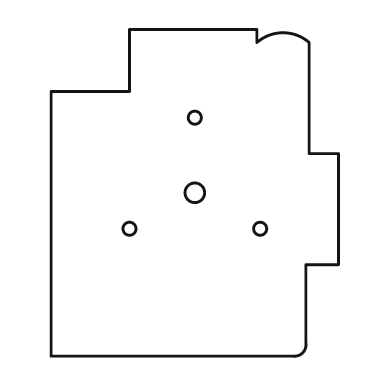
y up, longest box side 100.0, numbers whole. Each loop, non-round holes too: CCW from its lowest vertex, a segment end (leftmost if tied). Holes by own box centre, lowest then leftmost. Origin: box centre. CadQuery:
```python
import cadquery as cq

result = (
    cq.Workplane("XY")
    .moveTo(-44.0, -50.0)
    .lineTo(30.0, -50.0)
    .threePointArc((33.0, -49.0), (34.0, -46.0))
    .lineTo(34.0, -22.0)
    .lineTo(44.0, -22.0)
    .lineTo(44.0, 12.0)
    .lineTo(35.0, 12.0)
    .lineTo(35.0, 46.0)
    .threePointArc((27.0, 49.0), (19.0, 46.0))
    .lineTo(19.0, 50.0)
    .lineTo(-20.0, 50.0)
    .lineTo(-20.0, 31.0)
    .lineTo(-44.0, 31.0)
    .close()
    .moveTo(-20.0, -11.0)
    .circle(2.0)
    .moveTo(20.0, -11.0)
    .circle(2.0)
    .moveTo(0.0, 0.0)
    .circle(3.0)
    .moveTo(0.0, 23.0)
    .circle(2.0)
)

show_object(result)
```